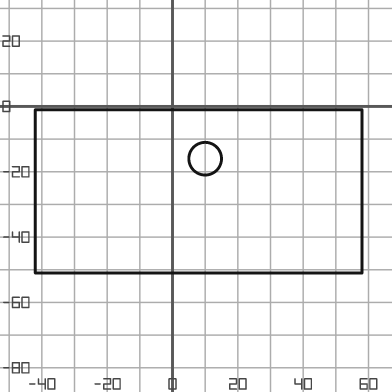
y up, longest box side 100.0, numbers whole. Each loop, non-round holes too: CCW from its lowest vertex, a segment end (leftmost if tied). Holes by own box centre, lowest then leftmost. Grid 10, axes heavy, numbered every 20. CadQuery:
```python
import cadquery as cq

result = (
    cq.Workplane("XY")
    .moveTo(-42.0, -51.0)
    .lineTo(58.0, -51.0)
    .lineTo(58.0, -1.0)
    .lineTo(-42.0, -1.0)
    .close()
    .moveTo(10.0, -16.0)
    .circle(5.0)
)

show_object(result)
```